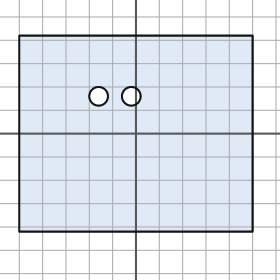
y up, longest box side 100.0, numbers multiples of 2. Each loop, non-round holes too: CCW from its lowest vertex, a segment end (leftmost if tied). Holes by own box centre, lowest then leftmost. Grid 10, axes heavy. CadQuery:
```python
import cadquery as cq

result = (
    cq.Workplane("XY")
    .moveTo(-50.0, -42.0)
    .lineTo(50.0, -42.0)
    .lineTo(50.0, 42.0)
    .lineTo(-50.0, 42.0)
    .close()
    .moveTo(-16.0, 16.0)
    .circle(4.0)
    .moveTo(-2.0, 16.0)
    .circle(4.0)
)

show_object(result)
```